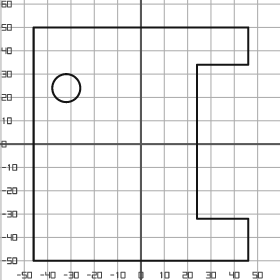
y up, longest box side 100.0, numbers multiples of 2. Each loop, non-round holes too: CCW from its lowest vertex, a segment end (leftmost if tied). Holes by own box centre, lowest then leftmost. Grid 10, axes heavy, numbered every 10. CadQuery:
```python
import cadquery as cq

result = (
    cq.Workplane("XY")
    .moveTo(-46.0, -50.0)
    .lineTo(46.0, -50.0)
    .lineTo(46.0, -32.0)
    .lineTo(24.0, -32.0)
    .lineTo(24.0, 34.0)
    .lineTo(46.0, 34.0)
    .lineTo(46.0, 50.0)
    .lineTo(-46.0, 50.0)
    .close()
    .moveTo(-32.0, 24.0)
    .circle(6.0)
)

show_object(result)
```